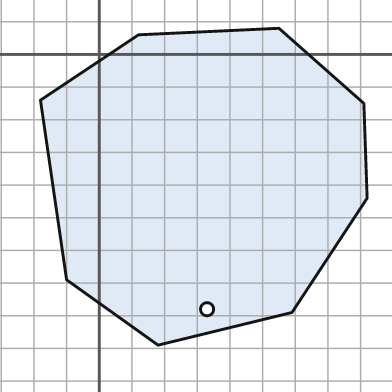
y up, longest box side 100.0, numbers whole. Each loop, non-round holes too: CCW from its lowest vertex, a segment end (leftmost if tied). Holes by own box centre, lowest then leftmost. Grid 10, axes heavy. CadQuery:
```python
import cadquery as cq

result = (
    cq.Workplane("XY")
    .moveTo(18.0, -89.0)
    .lineTo(59.0, -79.0)
    .lineTo(82.0, -44.0)
    .lineTo(81.0, -15.0)
    .lineTo(55.0, 8.0)
    .lineTo(12.0, 6.0)
    .lineTo(-18.0, -14.0)
    .lineTo(-10.0, -69.0)
    .close()
    .moveTo(33.0, -78.0)
    .circle(2.0)
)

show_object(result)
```